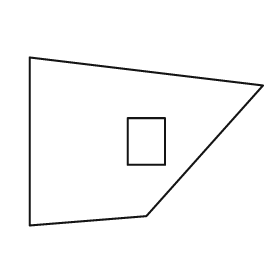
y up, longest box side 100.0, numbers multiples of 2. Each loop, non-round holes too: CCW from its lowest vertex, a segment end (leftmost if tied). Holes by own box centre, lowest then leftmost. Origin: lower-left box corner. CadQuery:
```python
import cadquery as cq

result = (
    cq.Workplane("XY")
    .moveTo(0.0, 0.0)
    .lineTo(50.0, 4.0)
    .lineTo(100.0, 60.0)
    .lineTo(0.0, 72.0)
    .close()
    .moveTo(42.0, 26.0)
    .lineTo(58.0, 26.0)
    .lineTo(58.0, 46.0)
    .lineTo(42.0, 46.0)
    .close()
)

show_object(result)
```